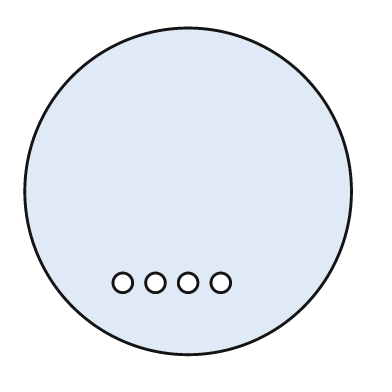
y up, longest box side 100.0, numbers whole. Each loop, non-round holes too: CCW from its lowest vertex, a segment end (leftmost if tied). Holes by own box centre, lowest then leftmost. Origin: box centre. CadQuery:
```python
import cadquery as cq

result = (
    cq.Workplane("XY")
    .moveTo(0.0, 0.0)
    .circle(50.0)
    .moveTo(-20.0, -28.0)
    .circle(3.0)
    .moveTo(-10.0, -28.0)
    .circle(3.0)
    .moveTo(0.0, -28.0)
    .circle(3.0)
    .moveTo(10.0, -28.0)
    .circle(3.0)
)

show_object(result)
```